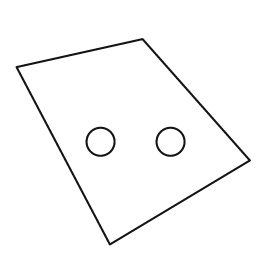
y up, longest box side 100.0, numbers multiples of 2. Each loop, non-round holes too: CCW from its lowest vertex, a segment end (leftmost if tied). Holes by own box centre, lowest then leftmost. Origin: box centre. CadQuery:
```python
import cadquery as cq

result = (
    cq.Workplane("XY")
    .moveTo(-10.0, -44.0)
    .lineTo(50.0, -8.0)
    .lineTo(4.0, 44.0)
    .lineTo(-50.0, 32.0)
    .close()
    .moveTo(-14.0, 0.0)
    .circle(6.0)
    .moveTo(16.0, 0.0)
    .circle(6.0)
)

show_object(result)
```